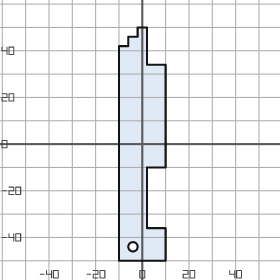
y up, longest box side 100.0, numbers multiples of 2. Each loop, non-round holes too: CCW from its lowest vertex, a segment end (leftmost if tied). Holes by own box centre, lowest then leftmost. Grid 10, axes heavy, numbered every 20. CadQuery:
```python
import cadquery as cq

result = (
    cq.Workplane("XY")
    .moveTo(-10.0, -50.0)
    .lineTo(10.0, -50.0)
    .lineTo(10.0, -36.0)
    .lineTo(2.0, -36.0)
    .lineTo(2.0, -10.0)
    .lineTo(10.0, -10.0)
    .lineTo(10.0, 34.0)
    .lineTo(2.0, 34.0)
    .lineTo(2.0, 50.0)
    .lineTo(-2.0, 50.0)
    .lineTo(-2.0, 46.0)
    .lineTo(-6.0, 46.0)
    .lineTo(-6.0, 42.0)
    .lineTo(-10.0, 42.0)
    .close()
    .moveTo(-4.0, -44.0)
    .circle(2.0)
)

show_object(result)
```